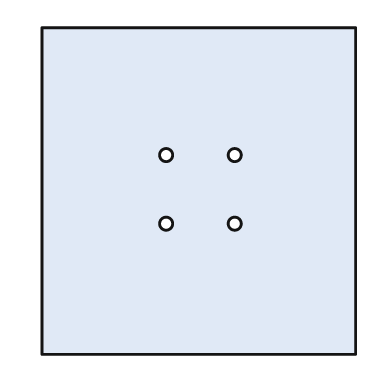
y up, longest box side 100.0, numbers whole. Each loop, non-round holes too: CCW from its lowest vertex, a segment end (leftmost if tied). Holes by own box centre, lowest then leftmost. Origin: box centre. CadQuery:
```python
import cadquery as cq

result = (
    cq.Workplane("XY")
    .moveTo(-48.0, -50.0)
    .lineTo(48.0, -50.0)
    .lineTo(48.0, 50.0)
    .lineTo(-48.0, 50.0)
    .close()
    .moveTo(-10.0, -10.0)
    .circle(2.0)
    .moveTo(11.0, -10.0)
    .circle(2.0)
    .moveTo(-10.0, 11.0)
    .circle(2.0)
    .moveTo(11.0, 11.0)
    .circle(2.0)
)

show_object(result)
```